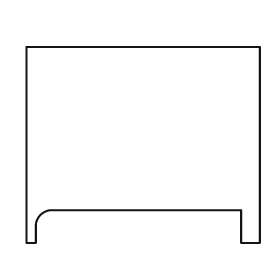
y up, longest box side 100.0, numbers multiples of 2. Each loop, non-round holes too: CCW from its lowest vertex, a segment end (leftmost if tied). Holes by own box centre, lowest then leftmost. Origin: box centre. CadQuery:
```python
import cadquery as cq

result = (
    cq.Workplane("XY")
    .moveTo(-50.0, -42.0)
    .lineTo(-46.0, -42.0)
    .lineTo(-46.0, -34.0)
    .threePointArc((-44.0, -30.0), (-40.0, -28.0))
    .lineTo(42.0, -28.0)
    .lineTo(42.0, -42.0)
    .lineTo(50.0, -42.0)
    .lineTo(50.0, 42.0)
    .lineTo(-50.0, 42.0)
    .close()
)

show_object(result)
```